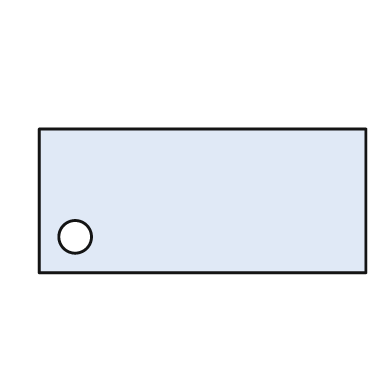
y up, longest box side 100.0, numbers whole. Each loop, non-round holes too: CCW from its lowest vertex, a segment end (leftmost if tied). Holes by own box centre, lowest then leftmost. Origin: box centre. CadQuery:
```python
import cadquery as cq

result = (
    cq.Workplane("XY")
    .moveTo(-50.0, -22.0)
    .lineTo(50.0, -22.0)
    .lineTo(50.0, 22.0)
    .lineTo(-50.0, 22.0)
    .close()
    .moveTo(-39.0, -11.0)
    .circle(5.0)
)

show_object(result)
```